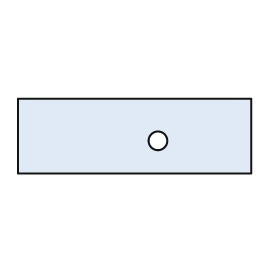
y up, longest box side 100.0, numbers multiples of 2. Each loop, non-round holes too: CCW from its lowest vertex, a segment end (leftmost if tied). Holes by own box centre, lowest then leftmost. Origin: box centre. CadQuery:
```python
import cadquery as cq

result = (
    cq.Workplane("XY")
    .moveTo(-50.0, -16.0)
    .lineTo(50.0, -16.0)
    .lineTo(50.0, 16.0)
    .lineTo(-50.0, 16.0)
    .close()
    .moveTo(10.0, -2.0)
    .circle(4.0)
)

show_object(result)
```